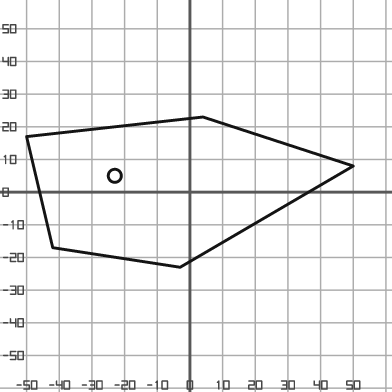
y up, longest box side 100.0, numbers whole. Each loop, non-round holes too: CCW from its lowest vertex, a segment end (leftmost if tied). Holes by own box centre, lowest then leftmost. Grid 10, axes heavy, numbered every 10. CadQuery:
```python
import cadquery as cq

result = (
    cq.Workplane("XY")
    .moveTo(-3.0, -23.0)
    .lineTo(50.0, 8.0)
    .lineTo(4.0, 23.0)
    .lineTo(-50.0, 17.0)
    .lineTo(-42.0, -17.0)
    .close()
    .moveTo(-23.0, 5.0)
    .circle(2.0)
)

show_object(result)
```